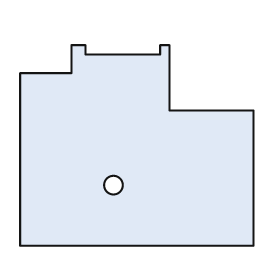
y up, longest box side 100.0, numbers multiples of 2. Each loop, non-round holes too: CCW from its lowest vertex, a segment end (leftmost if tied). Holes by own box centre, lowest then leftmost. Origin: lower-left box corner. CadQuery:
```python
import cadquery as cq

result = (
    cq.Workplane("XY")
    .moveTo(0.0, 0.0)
    .lineTo(100.0, 0.0)
    .lineTo(100.0, 58.0)
    .lineTo(64.0, 58.0)
    .lineTo(64.0, 86.0)
    .lineTo(60.0, 86.0)
    .lineTo(60.0, 82.0)
    .lineTo(28.0, 82.0)
    .lineTo(28.0, 86.0)
    .lineTo(22.0, 86.0)
    .lineTo(22.0, 74.0)
    .lineTo(0.0, 74.0)
    .close()
    .moveTo(40.0, 26.0)
    .circle(4.0)
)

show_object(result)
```